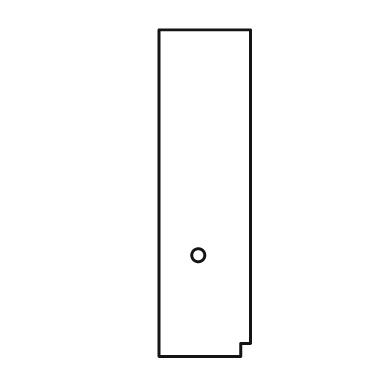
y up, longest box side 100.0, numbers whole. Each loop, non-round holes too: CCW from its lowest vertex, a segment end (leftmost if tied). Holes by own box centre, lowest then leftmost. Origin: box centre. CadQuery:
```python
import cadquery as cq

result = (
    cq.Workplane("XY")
    .moveTo(-14.0, -50.0)
    .lineTo(11.0, -50.0)
    .lineTo(11.0, -46.0)
    .lineTo(14.0, -46.0)
    .lineTo(14.0, 50.0)
    .lineTo(-14.0, 50.0)
    .close()
    .moveTo(-2.0, -19.0)
    .circle(2.0)
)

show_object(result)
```